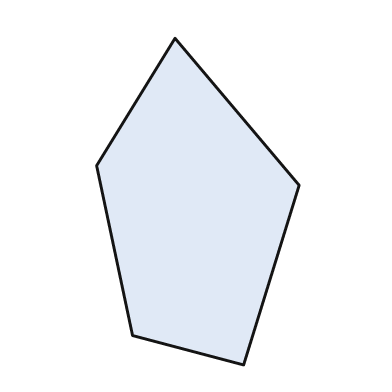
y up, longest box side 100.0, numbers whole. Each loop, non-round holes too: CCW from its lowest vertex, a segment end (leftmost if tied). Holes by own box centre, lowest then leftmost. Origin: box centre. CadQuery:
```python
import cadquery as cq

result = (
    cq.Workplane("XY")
    .moveTo(14.0, -50.0)
    .lineTo(31.0, 5.0)
    .lineTo(-7.0, 50.0)
    .lineTo(-31.0, 11.0)
    .lineTo(-20.0, -41.0)
    .close()
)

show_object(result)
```